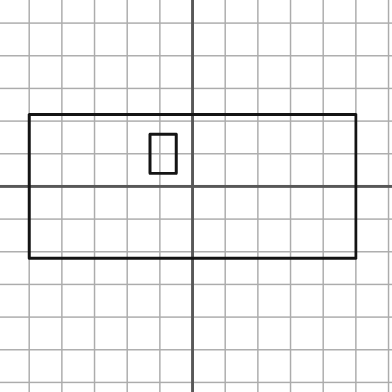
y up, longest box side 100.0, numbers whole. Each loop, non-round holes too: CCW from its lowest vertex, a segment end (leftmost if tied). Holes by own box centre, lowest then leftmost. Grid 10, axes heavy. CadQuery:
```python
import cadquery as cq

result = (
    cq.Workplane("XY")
    .moveTo(-50.0, -22.0)
    .lineTo(50.0, -22.0)
    .lineTo(50.0, 22.0)
    .lineTo(-50.0, 22.0)
    .close()
    .moveTo(-13.0, 4.0)
    .lineTo(-5.0, 4.0)
    .lineTo(-5.0, 16.0)
    .lineTo(-13.0, 16.0)
    .close()
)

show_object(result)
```